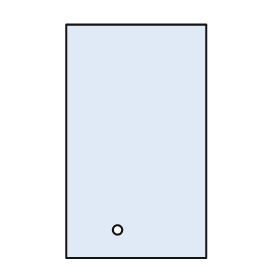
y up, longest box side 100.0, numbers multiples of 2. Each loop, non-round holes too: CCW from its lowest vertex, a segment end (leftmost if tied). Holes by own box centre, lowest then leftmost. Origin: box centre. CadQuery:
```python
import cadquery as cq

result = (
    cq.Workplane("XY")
    .moveTo(-30.0, -50.0)
    .lineTo(30.0, -50.0)
    .lineTo(30.0, 50.0)
    .lineTo(-30.0, 50.0)
    .close()
    .moveTo(-8.0, -38.0)
    .circle(2.0)
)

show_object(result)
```